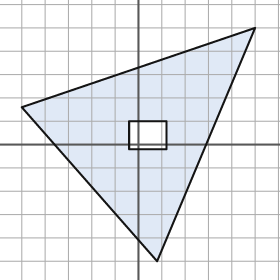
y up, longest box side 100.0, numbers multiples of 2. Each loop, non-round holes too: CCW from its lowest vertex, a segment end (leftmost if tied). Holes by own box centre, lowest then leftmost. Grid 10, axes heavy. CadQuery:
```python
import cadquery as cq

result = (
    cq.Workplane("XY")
    .moveTo(8.0, -50.0)
    .lineTo(50.0, 50.0)
    .lineTo(-50.0, 16.0)
    .close()
    .moveTo(-4.0, -2.0)
    .lineTo(12.0, -2.0)
    .lineTo(12.0, 10.0)
    .lineTo(-4.0, 10.0)
    .close()
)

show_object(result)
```